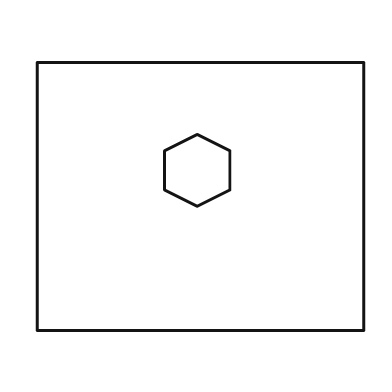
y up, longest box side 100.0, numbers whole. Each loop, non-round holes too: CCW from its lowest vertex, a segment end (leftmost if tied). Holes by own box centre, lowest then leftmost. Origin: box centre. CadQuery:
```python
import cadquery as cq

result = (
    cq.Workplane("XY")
    .moveTo(-50.0, -41.0)
    .lineTo(50.0, -41.0)
    .lineTo(50.0, 41.0)
    .lineTo(-50.0, 41.0)
    .close()
    .moveTo(-1.0, -3.0)
    .lineTo(9.0, 2.0)
    .lineTo(9.0, 14.0)
    .lineTo(-1.0, 19.0)
    .lineTo(-11.0, 14.0)
    .lineTo(-11.0, 2.0)
    .close()
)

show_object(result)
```